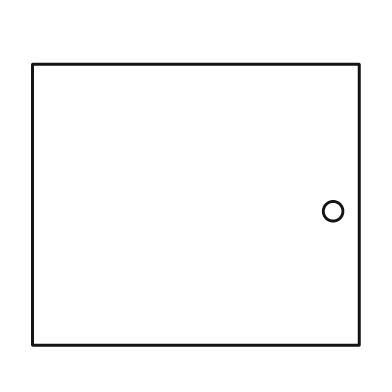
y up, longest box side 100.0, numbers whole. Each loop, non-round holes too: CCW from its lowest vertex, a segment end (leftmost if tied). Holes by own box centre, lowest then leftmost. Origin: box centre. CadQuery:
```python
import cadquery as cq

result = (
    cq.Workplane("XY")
    .moveTo(-50.0, -43.0)
    .lineTo(50.0, -43.0)
    .lineTo(50.0, 43.0)
    .lineTo(-50.0, 43.0)
    .close()
    .moveTo(42.0, -2.0)
    .circle(3.0)
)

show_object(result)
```